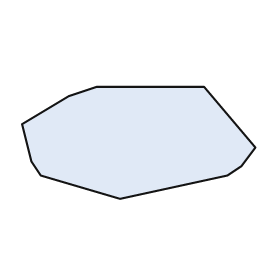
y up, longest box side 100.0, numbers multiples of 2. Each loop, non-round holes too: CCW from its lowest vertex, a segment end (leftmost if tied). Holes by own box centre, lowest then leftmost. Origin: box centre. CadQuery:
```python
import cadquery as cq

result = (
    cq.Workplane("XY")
    .moveTo(-8.0, -24.0)
    .lineTo(38.0, -14.0)
    .lineTo(44.0, -10.0)
    .lineTo(50.0, -2.0)
    .lineTo(28.0, 24.0)
    .lineTo(-18.0, 24.0)
    .lineTo(-30.0, 20.0)
    .lineTo(-50.0, 8.0)
    .lineTo(-46.0, -8.0)
    .lineTo(-42.0, -14.0)
    .close()
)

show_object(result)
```